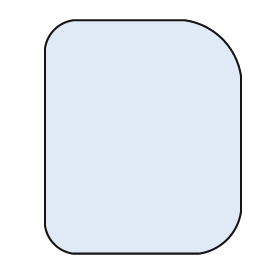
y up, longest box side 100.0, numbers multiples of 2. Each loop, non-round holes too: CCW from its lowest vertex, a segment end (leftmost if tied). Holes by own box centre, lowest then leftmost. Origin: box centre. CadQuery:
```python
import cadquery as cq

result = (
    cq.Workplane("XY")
    .moveTo(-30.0, -50.0)
    .lineTo(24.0, -50.0)
    .threePointArc((36.0, -44.0), (42.0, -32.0))
    .lineTo(42.0, 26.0)
    .threePointArc((34.0, 42.0), (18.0, 50.0))
    .lineTo(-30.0, 50.0)
    .threePointArc((-38.0, 46.0), (-42.0, 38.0))
    .lineTo(-42.0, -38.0)
    .threePointArc((-38.0, -46.0), (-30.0, -50.0))
    .close()
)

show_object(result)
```